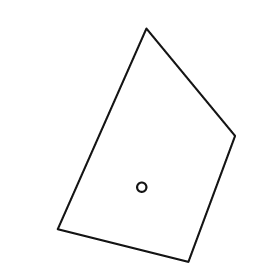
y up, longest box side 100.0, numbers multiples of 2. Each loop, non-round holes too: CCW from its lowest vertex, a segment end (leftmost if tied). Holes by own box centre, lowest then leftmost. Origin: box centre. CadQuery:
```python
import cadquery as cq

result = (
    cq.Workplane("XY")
    .moveTo(18.0, -50.0)
    .lineTo(38.0, 4.0)
    .lineTo(0.0, 50.0)
    .lineTo(-38.0, -36.0)
    .close()
    .moveTo(-2.0, -18.0)
    .circle(2.0)
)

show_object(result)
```